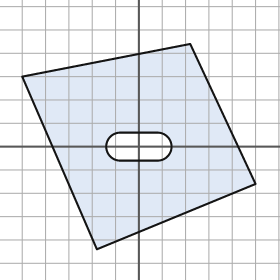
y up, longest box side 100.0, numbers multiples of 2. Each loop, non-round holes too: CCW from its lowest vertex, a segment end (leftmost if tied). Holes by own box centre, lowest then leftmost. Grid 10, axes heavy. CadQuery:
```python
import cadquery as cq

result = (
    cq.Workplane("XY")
    .moveTo(-18.0, -44.0)
    .lineTo(50.0, -16.0)
    .lineTo(22.0, 44.0)
    .lineTo(-50.0, 30.0)
    .close()
    .moveTo(-8.0, -6.0)
    .lineTo(8.0, -6.0)
    .threePointArc((14.0, 0.0), (8.0, 6.0))
    .lineTo(-8.0, 6.0)
    .threePointArc((-14.0, 0.0), (-8.0, -6.0))
    .close()
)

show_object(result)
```